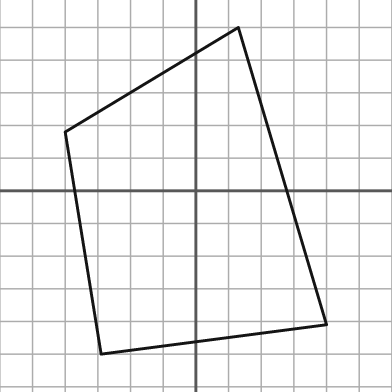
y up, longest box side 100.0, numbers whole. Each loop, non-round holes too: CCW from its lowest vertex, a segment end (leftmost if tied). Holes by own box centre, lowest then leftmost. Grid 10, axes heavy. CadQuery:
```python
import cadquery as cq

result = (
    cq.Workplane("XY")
    .moveTo(-29.0, -50.0)
    .lineTo(40.0, -41.0)
    .lineTo(13.0, 50.0)
    .lineTo(-40.0, 18.0)
    .close()
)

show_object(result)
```